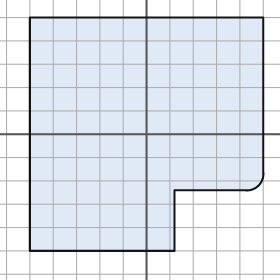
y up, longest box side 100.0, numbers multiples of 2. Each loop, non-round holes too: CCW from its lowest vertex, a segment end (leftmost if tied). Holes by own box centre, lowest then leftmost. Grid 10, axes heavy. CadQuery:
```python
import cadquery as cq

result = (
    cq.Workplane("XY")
    .moveTo(-50.0, -50.0)
    .lineTo(12.0, -50.0)
    .lineTo(12.0, -24.0)
    .lineTo(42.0, -24.0)
    .threePointArc((48.0, -22.0), (50.0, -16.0))
    .lineTo(50.0, 50.0)
    .lineTo(-50.0, 50.0)
    .close()
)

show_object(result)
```